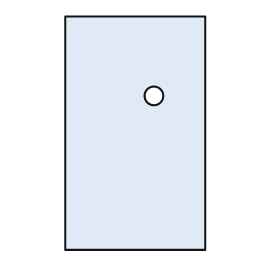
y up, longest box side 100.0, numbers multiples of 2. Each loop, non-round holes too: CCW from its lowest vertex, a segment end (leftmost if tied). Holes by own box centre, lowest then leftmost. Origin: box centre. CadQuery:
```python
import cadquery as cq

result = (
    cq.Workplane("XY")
    .moveTo(-30.0, -50.0)
    .lineTo(30.0, -50.0)
    .lineTo(30.0, 50.0)
    .lineTo(-30.0, 50.0)
    .close()
    .moveTo(8.0, 16.0)
    .circle(4.0)
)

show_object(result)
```